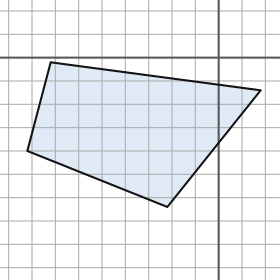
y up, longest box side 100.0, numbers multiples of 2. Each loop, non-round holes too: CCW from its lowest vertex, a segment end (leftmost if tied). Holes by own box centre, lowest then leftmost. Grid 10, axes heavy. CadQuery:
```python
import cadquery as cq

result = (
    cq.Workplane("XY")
    .moveTo(-22.0, -64.0)
    .lineTo(18.0, -14.0)
    .lineTo(-72.0, -2.0)
    .lineTo(-82.0, -40.0)
    .close()
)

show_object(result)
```